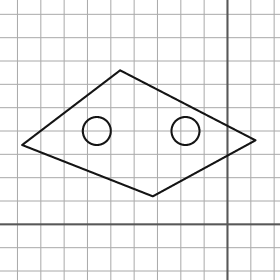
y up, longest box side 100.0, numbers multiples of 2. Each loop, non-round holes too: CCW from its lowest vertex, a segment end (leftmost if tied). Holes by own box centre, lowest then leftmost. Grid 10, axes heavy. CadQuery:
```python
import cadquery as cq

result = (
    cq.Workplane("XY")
    .moveTo(-32.0, 12.0)
    .lineTo(12.0, 36.0)
    .lineTo(-46.0, 66.0)
    .lineTo(-88.0, 34.0)
    .close()
    .moveTo(-56.0, 40.0)
    .circle(6.0)
    .moveTo(-18.0, 40.0)
    .circle(6.0)
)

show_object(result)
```